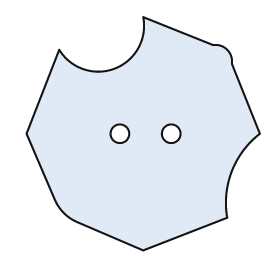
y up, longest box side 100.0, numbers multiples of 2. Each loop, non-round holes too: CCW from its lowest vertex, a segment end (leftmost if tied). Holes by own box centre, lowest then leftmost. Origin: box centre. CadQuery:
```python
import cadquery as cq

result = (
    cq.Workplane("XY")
    .moveTo(0.0, -50.0)
    .lineTo(36.0, -36.0)
    .threePointArc((38.0, -16.0), (50.0, 0.0))
    .lineTo(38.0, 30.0)
    .threePointArc((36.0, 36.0), (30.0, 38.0))
    .lineTo(0.0, 50.0)
    .threePointArc((-12.0, 28.0), (-36.0, 36.0))
    .lineTo(-50.0, 0.0)
    .lineTo(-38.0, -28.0)
    .threePointArc((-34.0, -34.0), (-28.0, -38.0))
    .close()
    .moveTo(-10.0, 0.0)
    .circle(4.0)
    .moveTo(12.0, 0.0)
    .circle(4.0)
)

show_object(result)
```